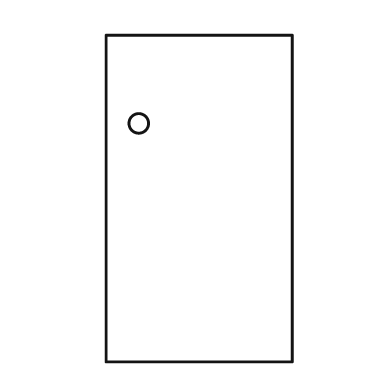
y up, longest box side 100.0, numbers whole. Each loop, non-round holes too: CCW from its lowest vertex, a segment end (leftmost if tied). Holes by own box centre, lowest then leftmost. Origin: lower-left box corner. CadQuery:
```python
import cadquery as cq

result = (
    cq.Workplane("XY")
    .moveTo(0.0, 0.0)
    .lineTo(57.0, 0.0)
    .lineTo(57.0, 100.0)
    .lineTo(0.0, 100.0)
    .close()
    .moveTo(10.0, 73.0)
    .circle(3.0)
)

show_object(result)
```